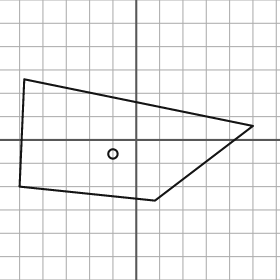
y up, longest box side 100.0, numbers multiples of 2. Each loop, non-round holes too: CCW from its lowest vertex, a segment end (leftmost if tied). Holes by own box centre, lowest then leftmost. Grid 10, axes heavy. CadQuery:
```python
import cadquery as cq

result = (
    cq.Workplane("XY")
    .moveTo(8.0, -26.0)
    .lineTo(50.0, 6.0)
    .lineTo(-48.0, 26.0)
    .lineTo(-50.0, -20.0)
    .close()
    .moveTo(-10.0, -6.0)
    .circle(2.0)
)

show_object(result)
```